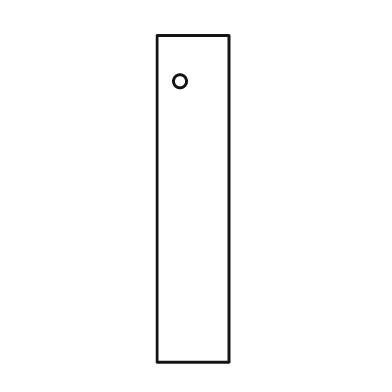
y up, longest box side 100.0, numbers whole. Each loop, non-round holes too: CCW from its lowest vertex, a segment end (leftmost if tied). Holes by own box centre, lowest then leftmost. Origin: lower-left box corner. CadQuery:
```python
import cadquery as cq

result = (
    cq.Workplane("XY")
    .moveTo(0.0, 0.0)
    .lineTo(22.0, 0.0)
    .lineTo(22.0, 100.0)
    .lineTo(0.0, 100.0)
    .close()
    .moveTo(7.0, 86.0)
    .circle(2.0)
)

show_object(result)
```